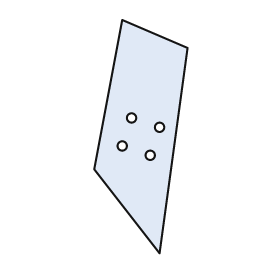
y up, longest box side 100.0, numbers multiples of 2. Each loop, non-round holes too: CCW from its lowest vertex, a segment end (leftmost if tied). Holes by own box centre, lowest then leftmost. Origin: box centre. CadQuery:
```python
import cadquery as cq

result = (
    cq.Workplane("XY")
    .moveTo(8.0, -50.0)
    .lineTo(20.0, 38.0)
    .lineTo(-8.0, 50.0)
    .lineTo(-20.0, -14.0)
    .close()
    .moveTo(4.0, -8.0)
    .circle(2.0)
    .moveTo(-8.0, -4.0)
    .circle(2.0)
    .moveTo(8.0, 4.0)
    .circle(2.0)
    .moveTo(-4.0, 8.0)
    .circle(2.0)
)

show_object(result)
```